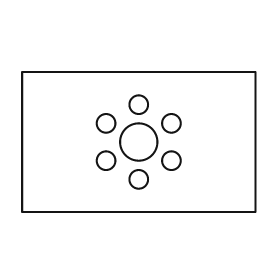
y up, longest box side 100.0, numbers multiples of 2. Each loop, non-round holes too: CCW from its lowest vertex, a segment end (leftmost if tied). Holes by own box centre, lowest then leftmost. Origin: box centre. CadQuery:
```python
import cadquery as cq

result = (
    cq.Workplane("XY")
    .moveTo(-50.0, -30.0)
    .lineTo(50.0, -30.0)
    .lineTo(50.0, 30.0)
    .lineTo(-50.0, 30.0)
    .close()
    .moveTo(0.0, -16.0)
    .circle(4.0)
    .moveTo(-14.0, -8.0)
    .circle(4.0)
    .moveTo(14.0, -8.0)
    .circle(4.0)
    .moveTo(0.0, 0.0)
    .circle(8.0)
    .moveTo(-14.0, 8.0)
    .circle(4.0)
    .moveTo(14.0, 8.0)
    .circle(4.0)
    .moveTo(0.0, 16.0)
    .circle(4.0)
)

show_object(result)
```